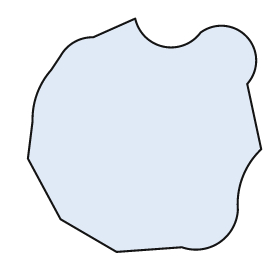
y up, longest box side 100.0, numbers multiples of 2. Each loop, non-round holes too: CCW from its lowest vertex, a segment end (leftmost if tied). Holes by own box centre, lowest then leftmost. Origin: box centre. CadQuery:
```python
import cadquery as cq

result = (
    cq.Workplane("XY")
    .moveTo(-12.0, -50.0)
    .lineTo(16.0, -48.0)
    .threePointArc((32.0, -46.0), (40.0, -32.0))
    .threePointArc((42.0, -18.0), (50.0, -6.0))
    .lineTo(44.0, 22.0)
    .threePointArc((44.0, 42.0), (24.0, 44.0))
    .threePointArc((8.0, 38.0), (-4.0, 50.0))
    .lineTo(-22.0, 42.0)
    .threePointArc((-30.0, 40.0), (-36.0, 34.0))
    .lineTo(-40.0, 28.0)
    .threePointArc((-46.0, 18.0), (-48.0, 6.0))
    .lineTo(-50.0, -10.0)
    .lineTo(-36.0, -36.0)
    .close()
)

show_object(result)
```